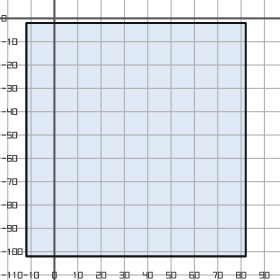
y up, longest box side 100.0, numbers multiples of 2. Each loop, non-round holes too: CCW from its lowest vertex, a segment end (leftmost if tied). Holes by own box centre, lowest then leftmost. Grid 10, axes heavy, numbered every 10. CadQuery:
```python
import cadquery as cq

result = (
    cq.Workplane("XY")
    .moveTo(-12.0, -102.0)
    .lineTo(82.0, -102.0)
    .lineTo(82.0, -2.0)
    .lineTo(-12.0, -2.0)
    .close()
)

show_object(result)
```